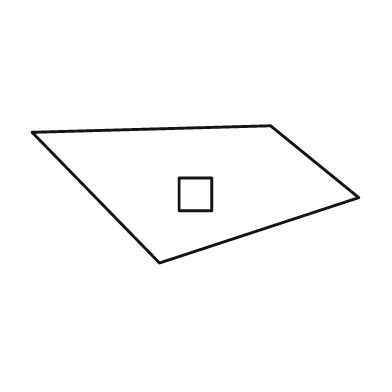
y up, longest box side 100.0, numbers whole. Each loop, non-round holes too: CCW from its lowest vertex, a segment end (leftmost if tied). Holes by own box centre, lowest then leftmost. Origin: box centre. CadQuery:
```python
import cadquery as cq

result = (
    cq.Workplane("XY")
    .moveTo(-11.0, -21.0)
    .lineTo(50.0, -1.0)
    .lineTo(23.0, 21.0)
    .lineTo(-50.0, 19.0)
    .close()
    .moveTo(-5.0, -5.0)
    .lineTo(5.0, -5.0)
    .lineTo(5.0, 5.0)
    .lineTo(-5.0, 5.0)
    .close()
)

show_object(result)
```